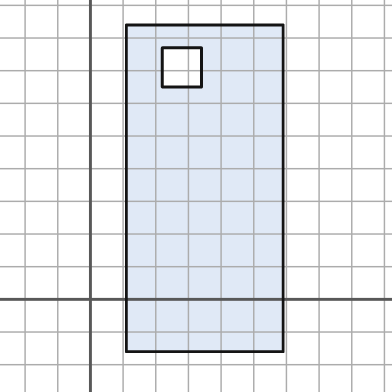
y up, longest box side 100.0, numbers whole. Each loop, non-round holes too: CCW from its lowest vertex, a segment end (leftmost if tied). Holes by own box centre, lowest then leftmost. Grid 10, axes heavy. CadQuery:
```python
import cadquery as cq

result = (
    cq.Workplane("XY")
    .moveTo(11.0, -16.0)
    .lineTo(59.0, -16.0)
    .lineTo(59.0, 84.0)
    .lineTo(11.0, 84.0)
    .close()
    .moveTo(22.0, 65.0)
    .lineTo(34.0, 65.0)
    .lineTo(34.0, 77.0)
    .lineTo(22.0, 77.0)
    .close()
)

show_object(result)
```